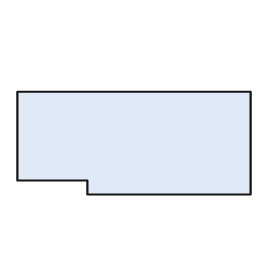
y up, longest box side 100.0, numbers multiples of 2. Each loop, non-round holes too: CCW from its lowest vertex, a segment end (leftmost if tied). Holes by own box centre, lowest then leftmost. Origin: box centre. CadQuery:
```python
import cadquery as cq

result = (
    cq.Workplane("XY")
    .moveTo(-20.0, -22.0)
    .lineTo(50.0, -22.0)
    .lineTo(50.0, 22.0)
    .lineTo(-50.0, 22.0)
    .lineTo(-50.0, -16.0)
    .lineTo(-20.0, -16.0)
    .close()
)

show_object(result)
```